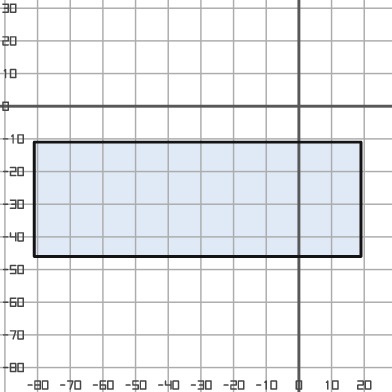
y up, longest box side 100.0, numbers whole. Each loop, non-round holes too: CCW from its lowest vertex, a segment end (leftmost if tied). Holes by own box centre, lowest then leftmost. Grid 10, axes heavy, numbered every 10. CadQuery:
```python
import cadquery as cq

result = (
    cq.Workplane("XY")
    .moveTo(-81.0, -46.0)
    .lineTo(19.0, -46.0)
    .lineTo(19.0, -11.0)
    .lineTo(-81.0, -11.0)
    .close()
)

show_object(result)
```